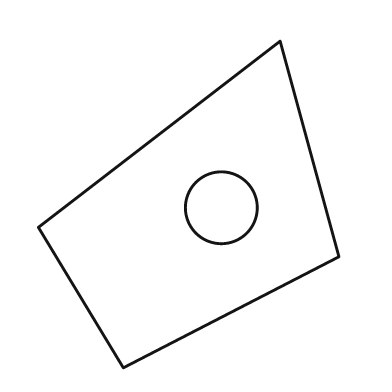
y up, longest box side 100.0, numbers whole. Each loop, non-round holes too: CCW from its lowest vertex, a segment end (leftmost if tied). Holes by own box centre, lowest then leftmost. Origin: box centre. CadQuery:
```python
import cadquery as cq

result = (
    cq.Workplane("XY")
    .moveTo(-20.0, -50.0)
    .lineTo(46.0, -16.0)
    .lineTo(28.0, 50.0)
    .lineTo(-46.0, -7.0)
    .close()
    .moveTo(10.0, -1.0)
    .circle(11.0)
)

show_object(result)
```